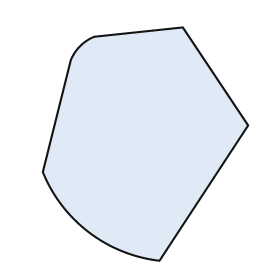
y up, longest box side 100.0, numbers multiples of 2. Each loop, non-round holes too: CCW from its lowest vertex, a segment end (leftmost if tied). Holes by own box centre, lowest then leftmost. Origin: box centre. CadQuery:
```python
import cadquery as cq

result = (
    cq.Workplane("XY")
    .moveTo(6.0, -50.0)
    .lineTo(44.0, 8.0)
    .lineTo(16.0, 50.0)
    .lineTo(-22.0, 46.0)
    .threePointArc((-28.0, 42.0), (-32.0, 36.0))
    .lineTo(-44.0, -12.0)
    .threePointArc((-24.0, -38.0), (6.0, -50.0))
    .close()
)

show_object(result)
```